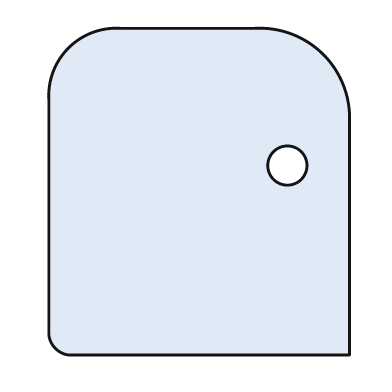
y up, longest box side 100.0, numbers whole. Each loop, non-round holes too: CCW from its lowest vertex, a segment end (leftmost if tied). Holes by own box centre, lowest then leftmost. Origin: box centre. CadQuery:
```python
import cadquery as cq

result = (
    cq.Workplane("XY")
    .moveTo(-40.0, -50.0)
    .lineTo(46.0, -50.0)
    .lineTo(46.0, 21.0)
    .threePointArc((38.0, 42.0), (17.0, 50.0))
    .lineTo(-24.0, 50.0)
    .threePointArc((-40.0, 44.0), (-46.0, 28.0))
    .lineTo(-46.0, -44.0)
    .threePointArc((-44.0, -48.0), (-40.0, -50.0))
    .close()
    .moveTo(27.0, 8.0)
    .circle(6.0)
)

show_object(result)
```